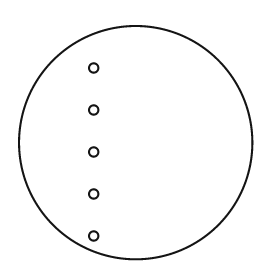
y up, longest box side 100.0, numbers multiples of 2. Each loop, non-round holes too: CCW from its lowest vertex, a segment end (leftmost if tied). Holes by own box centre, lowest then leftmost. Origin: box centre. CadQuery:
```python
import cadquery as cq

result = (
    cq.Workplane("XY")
    .moveTo(0.0, 0.0)
    .circle(50.0)
    .moveTo(-18.0, -40.0)
    .circle(2.0)
    .moveTo(-18.0, -22.0)
    .circle(2.0)
    .moveTo(-18.0, -4.0)
    .circle(2.0)
    .moveTo(-18.0, 14.0)
    .circle(2.0)
    .moveTo(-18.0, 32.0)
    .circle(2.0)
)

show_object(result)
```